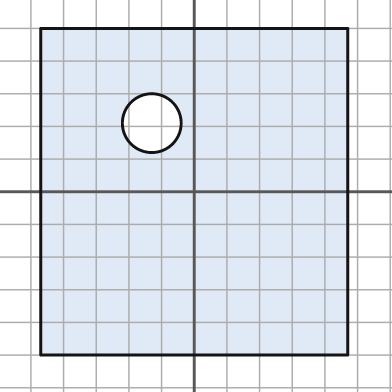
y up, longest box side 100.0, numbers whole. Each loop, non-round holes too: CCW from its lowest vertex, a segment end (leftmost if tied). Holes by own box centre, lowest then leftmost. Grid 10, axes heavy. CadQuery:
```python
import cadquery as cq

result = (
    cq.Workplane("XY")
    .moveTo(-47.0, -50.0)
    .lineTo(47.0, -50.0)
    .lineTo(47.0, 50.0)
    .lineTo(-47.0, 50.0)
    .close()
    .moveTo(-13.0, 21.0)
    .circle(9.0)
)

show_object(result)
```